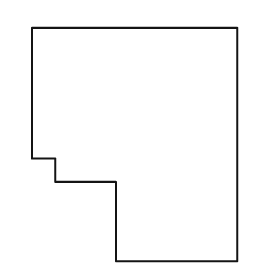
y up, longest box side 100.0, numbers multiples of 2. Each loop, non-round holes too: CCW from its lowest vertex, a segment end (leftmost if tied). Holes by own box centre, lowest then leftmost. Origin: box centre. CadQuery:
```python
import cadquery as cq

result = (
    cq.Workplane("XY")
    .moveTo(-8.0, -50.0)
    .lineTo(44.0, -50.0)
    .lineTo(44.0, 50.0)
    .lineTo(-44.0, 50.0)
    .lineTo(-44.0, -6.0)
    .lineTo(-34.0, -6.0)
    .lineTo(-34.0, -16.0)
    .lineTo(-8.0, -16.0)
    .close()
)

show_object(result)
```